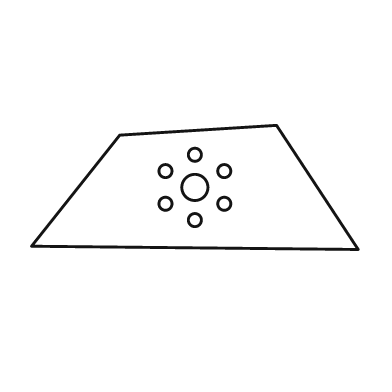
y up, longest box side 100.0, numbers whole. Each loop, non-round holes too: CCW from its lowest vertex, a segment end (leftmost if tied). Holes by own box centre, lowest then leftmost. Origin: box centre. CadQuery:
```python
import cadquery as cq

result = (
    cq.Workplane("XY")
    .moveTo(50.0, -19.0)
    .lineTo(25.0, 19.0)
    .lineTo(-23.0, 16.0)
    .lineTo(-50.0, -18.0)
    .close()
    .moveTo(0.0, -10.0)
    .circle(2.0)
    .moveTo(-9.0, -5.0)
    .circle(2.0)
    .moveTo(9.0, -5.0)
    .circle(2.0)
    .moveTo(0.0, 0.0)
    .circle(4.0)
    .moveTo(-9.0, 5.0)
    .circle(2.0)
    .moveTo(9.0, 5.0)
    .circle(2.0)
    .moveTo(0.0, 10.0)
    .circle(2.0)
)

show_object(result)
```